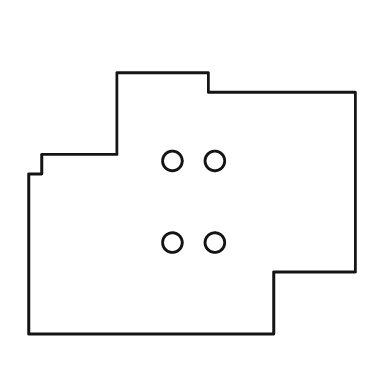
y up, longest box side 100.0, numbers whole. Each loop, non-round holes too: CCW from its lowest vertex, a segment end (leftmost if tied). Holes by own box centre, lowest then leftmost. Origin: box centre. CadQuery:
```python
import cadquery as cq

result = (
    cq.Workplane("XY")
    .moveTo(-50.0, -40.0)
    .lineTo(25.0, -40.0)
    .lineTo(25.0, -21.0)
    .lineTo(50.0, -21.0)
    .lineTo(50.0, 34.0)
    .lineTo(5.0, 34.0)
    .lineTo(5.0, 40.0)
    .lineTo(-23.0, 40.0)
    .lineTo(-23.0, 15.0)
    .lineTo(-46.0, 15.0)
    .lineTo(-46.0, 9.0)
    .lineTo(-50.0, 9.0)
    .close()
    .moveTo(-6.0, -12.0)
    .circle(3.0)
    .moveTo(7.0, -12.0)
    .circle(3.0)
    .moveTo(-6.0, 13.0)
    .circle(3.0)
    .moveTo(7.0, 13.0)
    .circle(3.0)
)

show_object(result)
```